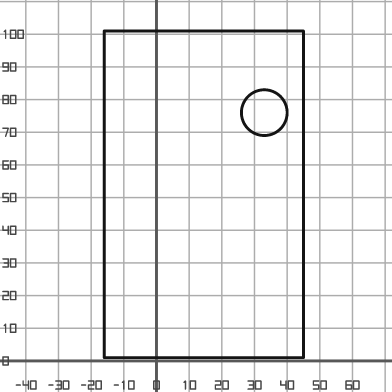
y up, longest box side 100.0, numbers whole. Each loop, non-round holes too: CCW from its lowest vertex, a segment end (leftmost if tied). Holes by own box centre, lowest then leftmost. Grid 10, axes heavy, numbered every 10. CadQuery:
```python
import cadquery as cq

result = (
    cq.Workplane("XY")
    .moveTo(-16.0, 1.0)
    .lineTo(45.0, 1.0)
    .lineTo(45.0, 101.0)
    .lineTo(-16.0, 101.0)
    .close()
    .moveTo(33.0, 76.0)
    .circle(7.0)
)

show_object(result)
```